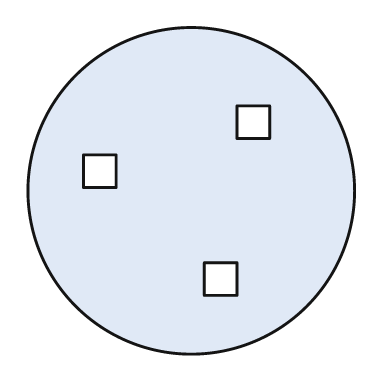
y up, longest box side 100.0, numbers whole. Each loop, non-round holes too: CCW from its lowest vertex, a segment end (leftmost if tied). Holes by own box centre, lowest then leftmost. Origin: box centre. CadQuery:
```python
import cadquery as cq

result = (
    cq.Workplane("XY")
    .moveTo(0.0, 0.0)
    .circle(50.0)
    .moveTo(4.0, -32.0)
    .lineTo(14.0, -32.0)
    .lineTo(14.0, -22.0)
    .lineTo(4.0, -22.0)
    .close()
    .moveTo(-33.0, 1.0)
    .lineTo(-23.0, 1.0)
    .lineTo(-23.0, 11.0)
    .lineTo(-33.0, 11.0)
    .close()
    .moveTo(14.0, 16.0)
    .lineTo(24.0, 16.0)
    .lineTo(24.0, 26.0)
    .lineTo(14.0, 26.0)
    .close()
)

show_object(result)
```